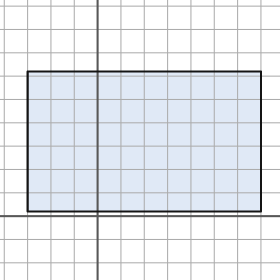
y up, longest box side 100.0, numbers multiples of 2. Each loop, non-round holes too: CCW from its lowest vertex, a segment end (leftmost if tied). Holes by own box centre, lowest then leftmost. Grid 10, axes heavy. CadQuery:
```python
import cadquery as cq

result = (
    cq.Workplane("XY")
    .moveTo(-30.0, 2.0)
    .lineTo(70.0, 2.0)
    .lineTo(70.0, 62.0)
    .lineTo(-30.0, 62.0)
    .close()
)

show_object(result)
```